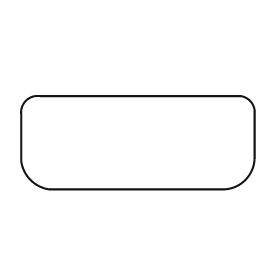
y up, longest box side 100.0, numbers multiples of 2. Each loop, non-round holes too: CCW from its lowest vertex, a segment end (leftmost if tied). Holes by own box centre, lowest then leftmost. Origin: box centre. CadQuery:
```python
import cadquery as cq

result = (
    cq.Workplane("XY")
    .moveTo(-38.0, -20.0)
    .lineTo(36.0, -20.0)
    .threePointArc((46.0, -16.0), (50.0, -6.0))
    .lineTo(50.0, 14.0)
    .threePointArc((48.0, 18.0), (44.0, 20.0))
    .lineTo(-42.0, 20.0)
    .threePointArc((-48.0, 18.0), (-50.0, 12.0))
    .lineTo(-50.0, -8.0)
    .threePointArc((-46.0, -16.0), (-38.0, -20.0))
    .close()
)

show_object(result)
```